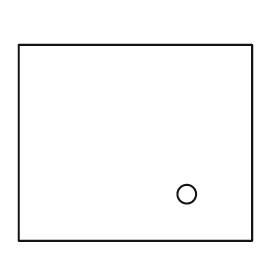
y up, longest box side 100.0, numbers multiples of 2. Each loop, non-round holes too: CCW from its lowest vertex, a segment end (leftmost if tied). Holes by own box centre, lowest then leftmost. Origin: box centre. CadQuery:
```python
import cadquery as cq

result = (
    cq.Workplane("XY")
    .moveTo(-50.0, -42.0)
    .lineTo(50.0, -42.0)
    .lineTo(50.0, 42.0)
    .lineTo(-50.0, 42.0)
    .close()
    .moveTo(22.0, -22.0)
    .circle(4.0)
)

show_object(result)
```